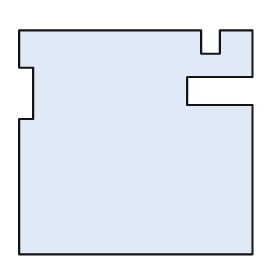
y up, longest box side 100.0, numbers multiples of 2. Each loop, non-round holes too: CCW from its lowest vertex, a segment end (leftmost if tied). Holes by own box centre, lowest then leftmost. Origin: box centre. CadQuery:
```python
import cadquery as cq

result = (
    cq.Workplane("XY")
    .moveTo(-50.0, -48.0)
    .lineTo(50.0, -48.0)
    .lineTo(50.0, 16.0)
    .lineTo(22.0, 16.0)
    .lineTo(22.0, 28.0)
    .lineTo(50.0, 28.0)
    .lineTo(50.0, 48.0)
    .lineTo(36.0, 48.0)
    .lineTo(36.0, 38.0)
    .lineTo(28.0, 38.0)
    .lineTo(28.0, 48.0)
    .lineTo(-50.0, 48.0)
    .lineTo(-50.0, 32.0)
    .lineTo(-44.0, 32.0)
    .lineTo(-44.0, 10.0)
    .lineTo(-50.0, 10.0)
    .close()
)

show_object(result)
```